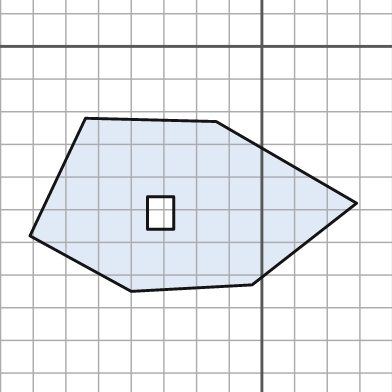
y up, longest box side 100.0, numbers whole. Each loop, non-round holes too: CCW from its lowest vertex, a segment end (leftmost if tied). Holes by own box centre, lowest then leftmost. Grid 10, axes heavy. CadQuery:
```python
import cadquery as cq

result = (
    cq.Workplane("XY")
    .moveTo(-40.0, -75.0)
    .lineTo(-3.0, -73.0)
    .lineTo(29.0, -48.0)
    .lineTo(-14.0, -23.0)
    .lineTo(-54.0, -22.0)
    .lineTo(-71.0, -58.0)
    .close()
    .moveTo(-35.0, -56.0)
    .lineTo(-27.0, -56.0)
    .lineTo(-27.0, -46.0)
    .lineTo(-35.0, -46.0)
    .close()
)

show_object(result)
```